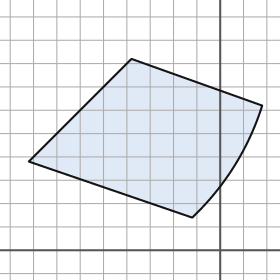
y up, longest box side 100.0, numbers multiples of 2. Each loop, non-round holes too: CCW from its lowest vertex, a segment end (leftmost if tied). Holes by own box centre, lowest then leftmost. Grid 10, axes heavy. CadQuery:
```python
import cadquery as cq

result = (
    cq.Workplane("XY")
    .moveTo(-12.0, 14.0)
    .threePointArc((6.0, 36.0), (18.0, 62.0))
    .lineTo(-38.0, 82.0)
    .lineTo(-82.0, 38.0)
    .close()
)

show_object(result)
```